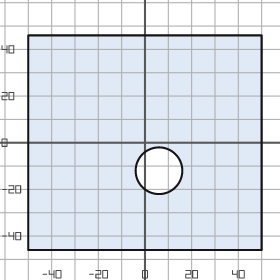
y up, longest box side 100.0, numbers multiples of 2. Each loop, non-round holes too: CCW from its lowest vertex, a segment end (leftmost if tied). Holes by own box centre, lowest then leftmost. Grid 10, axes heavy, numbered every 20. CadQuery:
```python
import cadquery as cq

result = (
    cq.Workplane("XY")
    .moveTo(-50.0, -46.0)
    .lineTo(50.0, -46.0)
    .lineTo(50.0, 46.0)
    .lineTo(-50.0, 46.0)
    .close()
    .moveTo(6.0, -12.0)
    .circle(10.0)
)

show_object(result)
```